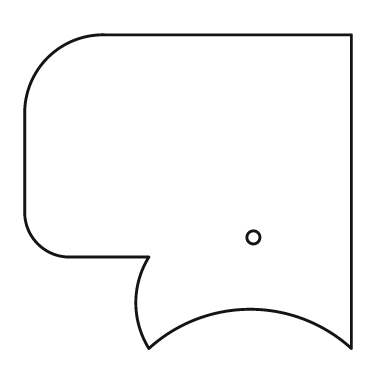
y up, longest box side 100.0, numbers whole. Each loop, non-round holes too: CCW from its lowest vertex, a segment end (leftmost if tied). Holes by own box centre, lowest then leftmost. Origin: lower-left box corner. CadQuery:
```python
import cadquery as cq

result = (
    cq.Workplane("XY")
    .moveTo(38.0, 0.0)
    .threePointArc((69.0, 12.0), (100.0, 0.0))
    .lineTo(100.0, 96.0)
    .lineTo(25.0, 96.0)
    .threePointArc((7.0, 89.0), (0.0, 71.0))
    .lineTo(0.0, 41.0)
    .threePointArc((4.0, 32.0), (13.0, 28.0))
    .lineTo(38.0, 28.0)
    .threePointArc((34.0, 14.0), (38.0, 0.0))
    .close()
    .moveTo(70.0, 34.0)
    .circle(2.0)
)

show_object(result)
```